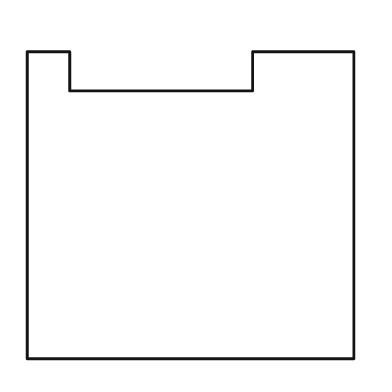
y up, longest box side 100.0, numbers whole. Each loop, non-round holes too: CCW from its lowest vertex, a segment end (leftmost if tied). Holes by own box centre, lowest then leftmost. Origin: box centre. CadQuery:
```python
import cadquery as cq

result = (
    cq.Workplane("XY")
    .moveTo(-50.0, -47.0)
    .lineTo(50.0, -47.0)
    .lineTo(50.0, 47.0)
    .lineTo(19.0, 47.0)
    .lineTo(19.0, 35.0)
    .lineTo(-37.0, 35.0)
    .lineTo(-37.0, 47.0)
    .lineTo(-50.0, 47.0)
    .close()
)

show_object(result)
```